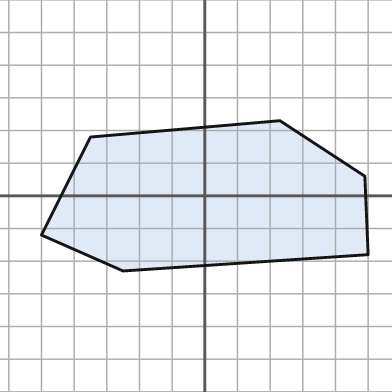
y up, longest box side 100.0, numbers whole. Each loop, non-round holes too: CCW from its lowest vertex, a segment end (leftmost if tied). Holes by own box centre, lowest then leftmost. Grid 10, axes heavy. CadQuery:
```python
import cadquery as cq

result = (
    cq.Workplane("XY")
    .moveTo(-25.0, -23.0)
    .lineTo(50.0, -18.0)
    .lineTo(49.0, 6.0)
    .lineTo(23.0, 23.0)
    .lineTo(-35.0, 18.0)
    .lineTo(-50.0, -12.0)
    .close()
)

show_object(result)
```